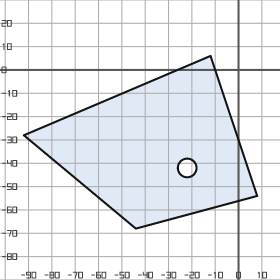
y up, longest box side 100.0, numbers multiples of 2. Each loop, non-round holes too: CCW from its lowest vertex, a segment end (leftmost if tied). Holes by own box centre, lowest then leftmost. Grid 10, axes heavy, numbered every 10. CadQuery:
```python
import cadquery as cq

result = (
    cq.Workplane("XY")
    .moveTo(-44.0, -68.0)
    .lineTo(8.0, -54.0)
    .lineTo(-12.0, 6.0)
    .lineTo(-92.0, -28.0)
    .close()
    .moveTo(-22.0, -42.0)
    .circle(4.0)
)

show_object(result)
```